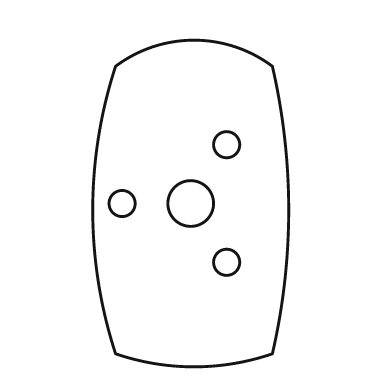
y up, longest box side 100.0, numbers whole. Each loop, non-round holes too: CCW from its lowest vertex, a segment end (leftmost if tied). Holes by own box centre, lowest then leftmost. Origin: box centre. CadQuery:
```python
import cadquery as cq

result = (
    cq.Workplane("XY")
    .moveTo(-23.0, -46.0)
    .threePointArc((1.0, -50.0), (25.0, -46.0))
    .threePointArc((30.0, -2.0), (25.0, 42.0))
    .threePointArc((1.0, 50.0), (-23.0, 42.0))
    .threePointArc((-30.0, -2.0), (-23.0, -46.0))
    .close()
    .moveTo(11.0, -18.0)
    .circle(4.0)
    .moveTo(-21.0, 0.0)
    .circle(4.0)
    .moveTo(0.0, 0.0)
    .circle(7.0)
    .moveTo(11.0, 18.0)
    .circle(4.0)
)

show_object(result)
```